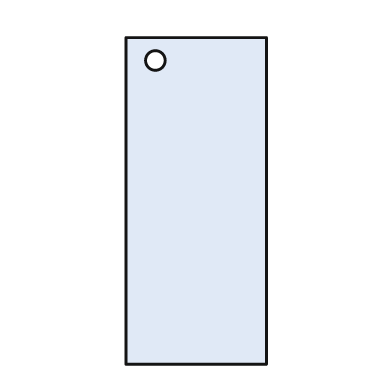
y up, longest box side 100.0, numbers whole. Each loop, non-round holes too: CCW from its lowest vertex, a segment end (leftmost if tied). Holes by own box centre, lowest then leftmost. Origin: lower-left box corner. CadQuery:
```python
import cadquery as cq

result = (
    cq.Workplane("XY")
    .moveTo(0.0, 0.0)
    .lineTo(43.0, 0.0)
    .lineTo(43.0, 100.0)
    .lineTo(0.0, 100.0)
    .close()
    .moveTo(9.0, 93.0)
    .circle(3.0)
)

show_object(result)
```